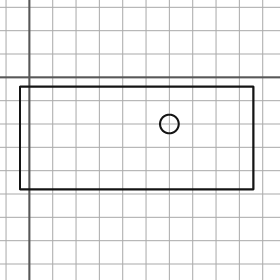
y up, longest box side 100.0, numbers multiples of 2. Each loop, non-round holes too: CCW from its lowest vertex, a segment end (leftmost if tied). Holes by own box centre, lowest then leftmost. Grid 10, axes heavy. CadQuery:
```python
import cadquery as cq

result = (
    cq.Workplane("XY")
    .moveTo(-4.0, -48.0)
    .lineTo(96.0, -48.0)
    .lineTo(96.0, -4.0)
    .lineTo(-4.0, -4.0)
    .close()
    .moveTo(60.0, -20.0)
    .circle(4.0)
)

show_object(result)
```